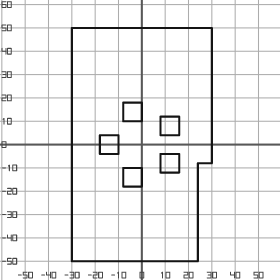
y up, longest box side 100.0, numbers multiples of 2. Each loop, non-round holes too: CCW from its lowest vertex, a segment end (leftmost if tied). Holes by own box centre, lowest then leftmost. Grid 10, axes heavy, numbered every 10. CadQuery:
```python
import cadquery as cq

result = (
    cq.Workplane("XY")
    .moveTo(-30.0, -50.0)
    .lineTo(24.0, -50.0)
    .lineTo(24.0, -8.0)
    .lineTo(30.0, -8.0)
    .lineTo(30.0, 50.0)
    .lineTo(-30.0, 50.0)
    .close()
    .moveTo(-8.0, -18.0)
    .lineTo(0.0, -18.0)
    .lineTo(0.0, -10.0)
    .lineTo(-8.0, -10.0)
    .close()
    .moveTo(8.0, -12.0)
    .lineTo(16.0, -12.0)
    .lineTo(16.0, -4.0)
    .lineTo(8.0, -4.0)
    .close()
    .moveTo(-18.0, -4.0)
    .lineTo(-10.0, -4.0)
    .lineTo(-10.0, 4.0)
    .lineTo(-18.0, 4.0)
    .close()
    .moveTo(8.0, 4.0)
    .lineTo(16.0, 4.0)
    .lineTo(16.0, 12.0)
    .lineTo(8.0, 12.0)
    .close()
    .moveTo(-8.0, 10.0)
    .lineTo(0.0, 10.0)
    .lineTo(0.0, 18.0)
    .lineTo(-8.0, 18.0)
    .close()
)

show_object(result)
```